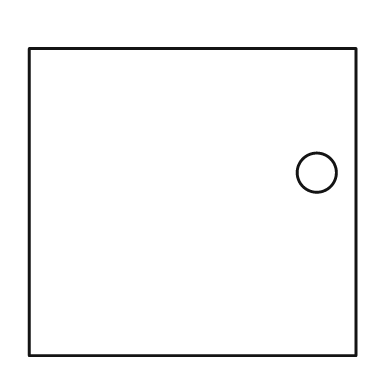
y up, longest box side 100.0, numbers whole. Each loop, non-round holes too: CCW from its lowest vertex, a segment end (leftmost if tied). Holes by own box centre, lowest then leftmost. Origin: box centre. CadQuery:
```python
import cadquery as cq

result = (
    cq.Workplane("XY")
    .moveTo(-50.0, -47.0)
    .lineTo(50.0, -47.0)
    .lineTo(50.0, 47.0)
    .lineTo(-50.0, 47.0)
    .close()
    .moveTo(38.0, 9.0)
    .circle(6.0)
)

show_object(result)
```